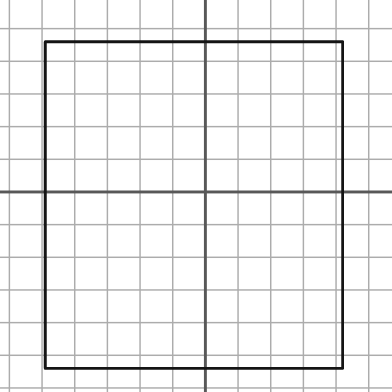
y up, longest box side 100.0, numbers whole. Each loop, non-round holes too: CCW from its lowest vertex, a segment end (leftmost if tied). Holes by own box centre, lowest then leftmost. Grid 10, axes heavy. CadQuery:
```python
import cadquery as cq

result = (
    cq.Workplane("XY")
    .moveTo(-49.0, -54.0)
    .lineTo(42.0, -54.0)
    .lineTo(42.0, 46.0)
    .lineTo(-49.0, 46.0)
    .close()
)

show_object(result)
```